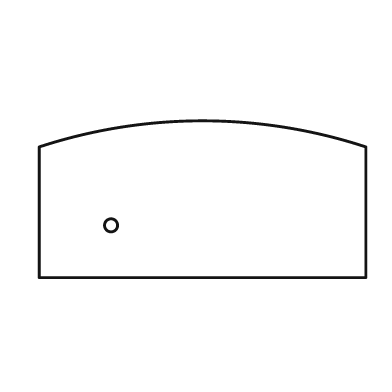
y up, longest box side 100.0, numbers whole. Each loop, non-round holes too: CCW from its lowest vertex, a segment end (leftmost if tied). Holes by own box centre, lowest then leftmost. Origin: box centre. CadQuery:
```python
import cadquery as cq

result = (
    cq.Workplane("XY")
    .moveTo(-50.0, -24.0)
    .lineTo(50.0, -24.0)
    .lineTo(50.0, 16.0)
    .threePointArc((0.0, 24.0), (-50.0, 16.0))
    .close()
    .moveTo(-28.0, -8.0)
    .circle(2.0)
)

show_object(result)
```